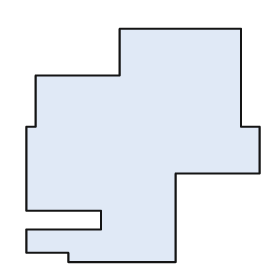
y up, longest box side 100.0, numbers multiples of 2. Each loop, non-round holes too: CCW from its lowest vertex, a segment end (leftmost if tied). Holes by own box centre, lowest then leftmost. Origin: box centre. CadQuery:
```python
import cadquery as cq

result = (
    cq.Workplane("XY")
    .moveTo(-32.0, -50.0)
    .lineTo(14.0, -50.0)
    .lineTo(14.0, -12.0)
    .lineTo(50.0, -12.0)
    .lineTo(50.0, 8.0)
    .lineTo(42.0, 8.0)
    .lineTo(42.0, 50.0)
    .lineTo(-10.0, 50.0)
    .lineTo(-10.0, 30.0)
    .lineTo(-46.0, 30.0)
    .lineTo(-46.0, 8.0)
    .lineTo(-50.0, 8.0)
    .lineTo(-50.0, -28.0)
    .lineTo(-18.0, -28.0)
    .lineTo(-18.0, -36.0)
    .lineTo(-50.0, -36.0)
    .lineTo(-50.0, -46.0)
    .lineTo(-32.0, -46.0)
    .close()
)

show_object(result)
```